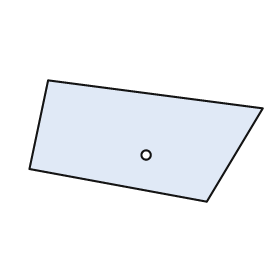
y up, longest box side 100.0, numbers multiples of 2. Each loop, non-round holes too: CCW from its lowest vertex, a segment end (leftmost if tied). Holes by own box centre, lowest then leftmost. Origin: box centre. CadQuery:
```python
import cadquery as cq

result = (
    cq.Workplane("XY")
    .moveTo(26.0, -26.0)
    .lineTo(50.0, 14.0)
    .lineTo(-42.0, 26.0)
    .lineTo(-50.0, -12.0)
    .close()
    .moveTo(0.0, -6.0)
    .circle(2.0)
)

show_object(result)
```